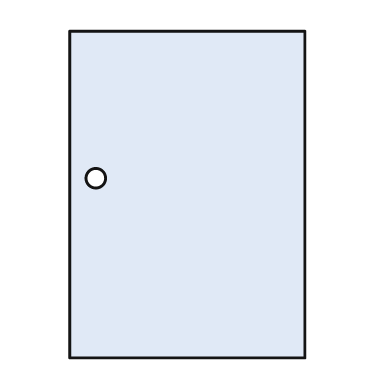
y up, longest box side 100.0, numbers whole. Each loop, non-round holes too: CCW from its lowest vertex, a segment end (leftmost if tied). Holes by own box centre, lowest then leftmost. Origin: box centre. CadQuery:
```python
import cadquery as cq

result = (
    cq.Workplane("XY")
    .moveTo(-36.0, -50.0)
    .lineTo(36.0, -50.0)
    .lineTo(36.0, 50.0)
    .lineTo(-36.0, 50.0)
    .close()
    .moveTo(-28.0, 5.0)
    .circle(3.0)
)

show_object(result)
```